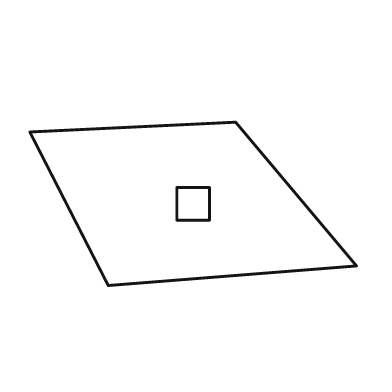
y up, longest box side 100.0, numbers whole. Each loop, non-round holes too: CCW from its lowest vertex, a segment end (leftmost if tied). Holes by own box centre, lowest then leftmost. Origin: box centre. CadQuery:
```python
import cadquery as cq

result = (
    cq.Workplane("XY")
    .moveTo(-26.0, -25.0)
    .lineTo(50.0, -19.0)
    .lineTo(13.0, 25.0)
    .lineTo(-50.0, 22.0)
    .close()
    .moveTo(-5.0, -5.0)
    .lineTo(5.0, -5.0)
    .lineTo(5.0, 5.0)
    .lineTo(-5.0, 5.0)
    .close()
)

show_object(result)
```